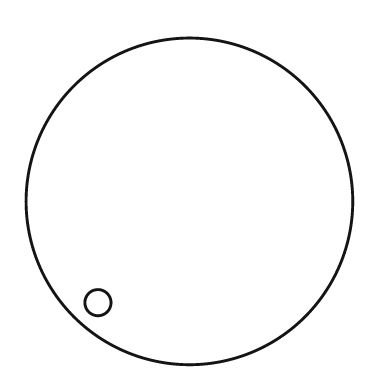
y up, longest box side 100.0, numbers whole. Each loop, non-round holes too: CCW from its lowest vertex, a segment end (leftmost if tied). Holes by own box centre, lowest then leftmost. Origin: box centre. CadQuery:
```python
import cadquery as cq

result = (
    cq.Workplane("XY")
    .moveTo(0.0, 0.0)
    .circle(50.0)
    .moveTo(-28.0, -31.0)
    .circle(4.0)
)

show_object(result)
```